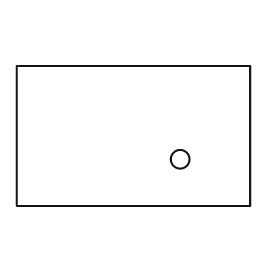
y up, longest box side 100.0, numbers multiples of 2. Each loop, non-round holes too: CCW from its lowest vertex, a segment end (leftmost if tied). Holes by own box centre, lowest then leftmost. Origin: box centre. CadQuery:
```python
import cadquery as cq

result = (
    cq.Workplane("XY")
    .moveTo(-50.0, -30.0)
    .lineTo(50.0, -30.0)
    .lineTo(50.0, 30.0)
    .lineTo(-50.0, 30.0)
    .close()
    .moveTo(20.0, -10.0)
    .circle(4.0)
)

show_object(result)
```